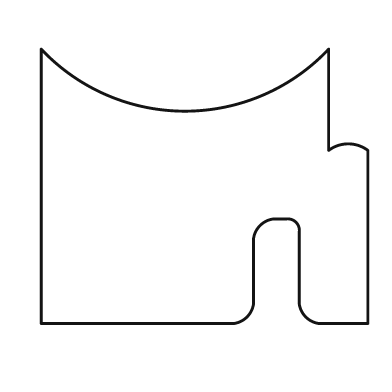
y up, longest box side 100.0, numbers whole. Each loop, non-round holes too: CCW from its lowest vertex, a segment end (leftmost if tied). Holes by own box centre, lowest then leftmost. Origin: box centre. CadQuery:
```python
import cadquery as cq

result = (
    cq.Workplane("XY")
    .moveTo(-50.0, -42.0)
    .lineTo(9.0, -42.0)
    .threePointArc((13.0, -40.0), (15.0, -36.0))
    .lineTo(15.0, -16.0)
    .threePointArc((17.0, -12.0), (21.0, -10.0))
    .lineTo(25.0, -10.0)
    .threePointArc((28.0, -11.0), (29.0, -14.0))
    .lineTo(29.0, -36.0)
    .threePointArc((31.0, -40.0), (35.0, -42.0))
    .lineTo(50.0, -42.0)
    .lineTo(50.0, 11.0)
    .threePointArc((44.0, 13.0), (38.0, 11.0))
    .lineTo(38.0, 42.0)
    .threePointArc((-6.0, 23.0), (-50.0, 42.0))
    .close()
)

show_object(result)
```